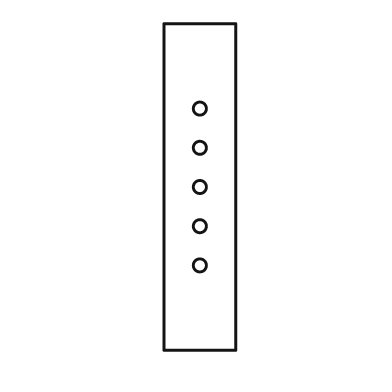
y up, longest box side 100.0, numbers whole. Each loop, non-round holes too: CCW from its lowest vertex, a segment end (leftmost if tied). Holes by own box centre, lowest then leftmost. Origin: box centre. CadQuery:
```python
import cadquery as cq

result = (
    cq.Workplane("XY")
    .moveTo(-11.0, -50.0)
    .lineTo(11.0, -50.0)
    .lineTo(11.0, 50.0)
    .lineTo(-11.0, 50.0)
    .close()
    .moveTo(0.0, -24.0)
    .circle(2.0)
    .moveTo(0.0, -12.0)
    .circle(2.0)
    .moveTo(0.0, 0.0)
    .circle(2.0)
    .moveTo(0.0, 12.0)
    .circle(2.0)
    .moveTo(0.0, 24.0)
    .circle(2.0)
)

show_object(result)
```